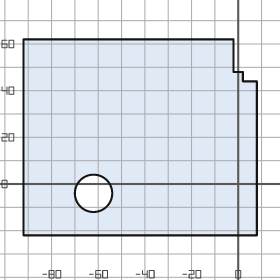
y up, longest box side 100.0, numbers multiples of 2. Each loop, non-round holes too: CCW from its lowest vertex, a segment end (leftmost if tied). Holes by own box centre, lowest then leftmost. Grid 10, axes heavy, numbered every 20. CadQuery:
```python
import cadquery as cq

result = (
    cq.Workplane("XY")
    .moveTo(-92.0, -22.0)
    .lineTo(8.0, -22.0)
    .lineTo(8.0, 44.0)
    .lineTo(2.0, 44.0)
    .lineTo(2.0, 48.0)
    .lineTo(-2.0, 48.0)
    .lineTo(-2.0, 62.0)
    .lineTo(-92.0, 62.0)
    .close()
    .moveTo(-62.0, -4.0)
    .circle(8.0)
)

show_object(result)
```